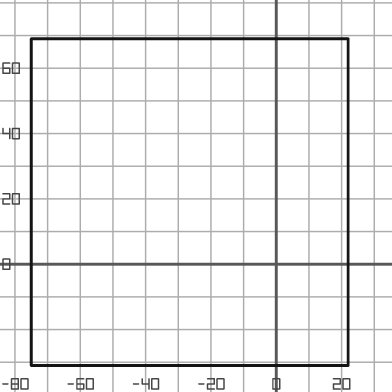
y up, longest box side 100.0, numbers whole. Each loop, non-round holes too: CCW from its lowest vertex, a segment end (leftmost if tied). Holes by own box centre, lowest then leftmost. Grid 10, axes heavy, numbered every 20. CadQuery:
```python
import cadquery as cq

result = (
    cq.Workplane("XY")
    .moveTo(-75.0, -31.0)
    .lineTo(22.0, -31.0)
    .lineTo(22.0, 69.0)
    .lineTo(-75.0, 69.0)
    .close()
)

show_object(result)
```